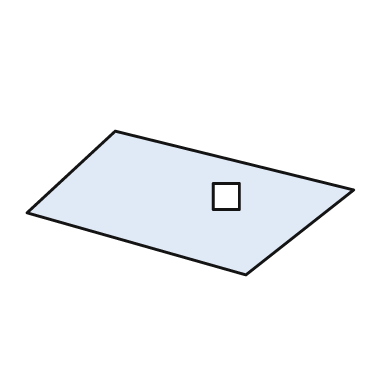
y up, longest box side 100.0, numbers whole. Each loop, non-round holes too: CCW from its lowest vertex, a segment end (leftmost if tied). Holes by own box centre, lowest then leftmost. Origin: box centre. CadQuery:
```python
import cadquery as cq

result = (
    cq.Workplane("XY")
    .moveTo(17.0, -22.0)
    .lineTo(50.0, 4.0)
    .lineTo(-23.0, 22.0)
    .lineTo(-50.0, -3.0)
    .close()
    .moveTo(7.0, -2.0)
    .lineTo(15.0, -2.0)
    .lineTo(15.0, 6.0)
    .lineTo(7.0, 6.0)
    .close()
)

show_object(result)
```